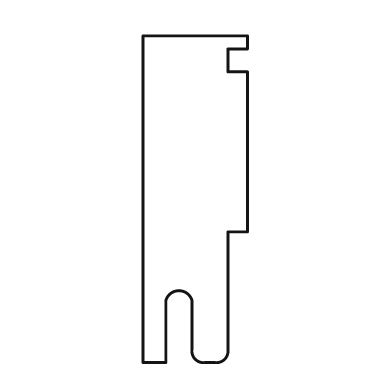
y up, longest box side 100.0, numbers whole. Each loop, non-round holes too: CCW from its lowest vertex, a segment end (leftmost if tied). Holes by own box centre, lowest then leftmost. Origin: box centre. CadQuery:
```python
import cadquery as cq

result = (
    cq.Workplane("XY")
    .moveTo(-16.0, -50.0)
    .lineTo(-9.0, -50.0)
    .lineTo(-9.0, -31.0)
    .threePointArc((-5.0, -28.0), (-1.0, -31.0))
    .lineTo(-1.0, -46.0)
    .threePointArc((0.0, -49.0), (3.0, -50.0))
    .lineTo(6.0, -50.0)
    .threePointArc((9.0, -49.0), (10.0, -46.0))
    .lineTo(10.0, -10.0)
    .lineTo(16.0, -10.0)
    .lineTo(16.0, 39.0)
    .lineTo(10.0, 39.0)
    .lineTo(10.0, 46.0)
    .lineTo(16.0, 46.0)
    .lineTo(16.0, 50.0)
    .lineTo(-16.0, 50.0)
    .close()
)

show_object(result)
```